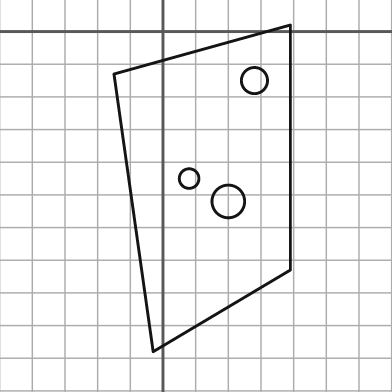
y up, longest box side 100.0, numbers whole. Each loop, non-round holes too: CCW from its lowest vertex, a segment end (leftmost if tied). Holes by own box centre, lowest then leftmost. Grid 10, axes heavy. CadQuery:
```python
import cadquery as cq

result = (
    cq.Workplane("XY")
    .moveTo(-3.0, -98.0)
    .lineTo(39.0, -73.0)
    .lineTo(39.0, 2.0)
    .lineTo(-15.0, -13.0)
    .close()
    .moveTo(20.0, -52.0)
    .circle(5.0)
    .moveTo(8.0, -45.0)
    .circle(3.0)
    .moveTo(28.0, -15.0)
    .circle(4.0)
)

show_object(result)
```